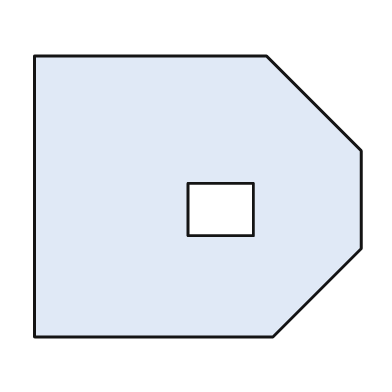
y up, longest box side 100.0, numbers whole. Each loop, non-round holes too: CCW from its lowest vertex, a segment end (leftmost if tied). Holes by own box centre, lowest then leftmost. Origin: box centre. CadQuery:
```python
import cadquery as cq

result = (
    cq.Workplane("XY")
    .moveTo(-50.0, -43.0)
    .lineTo(23.0, -43.0)
    .lineTo(50.0, -16.0)
    .lineTo(50.0, 14.0)
    .lineTo(21.0, 43.0)
    .lineTo(-50.0, 43.0)
    .close()
    .moveTo(-3.0, -12.0)
    .lineTo(17.0, -12.0)
    .lineTo(17.0, 4.0)
    .lineTo(-3.0, 4.0)
    .close()
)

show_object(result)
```